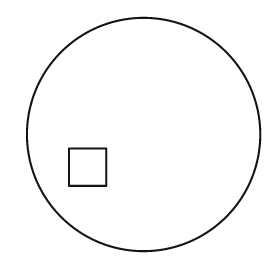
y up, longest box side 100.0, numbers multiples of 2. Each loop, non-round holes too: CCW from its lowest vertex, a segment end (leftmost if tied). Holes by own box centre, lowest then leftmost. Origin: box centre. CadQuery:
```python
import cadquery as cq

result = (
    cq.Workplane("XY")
    .moveTo(0.0, 0.0)
    .circle(50.0)
    .moveTo(-32.0, -22.0)
    .lineTo(-16.0, -22.0)
    .lineTo(-16.0, -6.0)
    .lineTo(-32.0, -6.0)
    .close()
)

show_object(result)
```